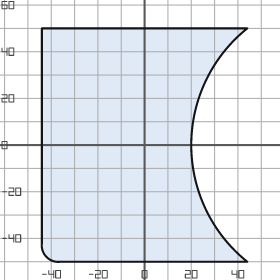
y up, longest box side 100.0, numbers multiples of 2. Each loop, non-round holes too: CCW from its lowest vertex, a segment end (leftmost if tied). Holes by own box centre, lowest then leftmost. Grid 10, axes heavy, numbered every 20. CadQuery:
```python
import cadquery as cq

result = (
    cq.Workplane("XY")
    .moveTo(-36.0, -50.0)
    .lineTo(44.0, -50.0)
    .threePointArc((20.0, 0.0), (44.0, 50.0))
    .lineTo(-44.0, 50.0)
    .lineTo(-44.0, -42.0)
    .threePointArc((-42.0, -48.0), (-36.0, -50.0))
    .close()
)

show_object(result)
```